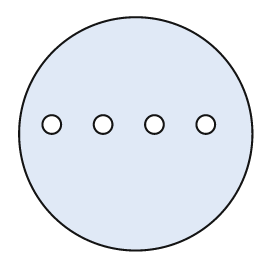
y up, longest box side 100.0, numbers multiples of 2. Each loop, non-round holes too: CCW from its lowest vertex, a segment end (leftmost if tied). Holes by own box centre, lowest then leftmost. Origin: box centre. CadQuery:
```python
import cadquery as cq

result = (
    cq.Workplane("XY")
    .moveTo(0.0, 0.0)
    .circle(50.0)
    .moveTo(-36.0, 4.0)
    .circle(4.0)
    .moveTo(-14.0, 4.0)
    .circle(4.0)
    .moveTo(8.0, 4.0)
    .circle(4.0)
    .moveTo(30.0, 4.0)
    .circle(4.0)
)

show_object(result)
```